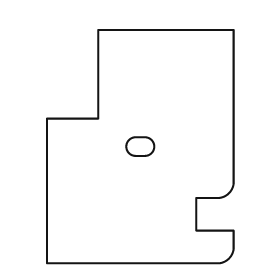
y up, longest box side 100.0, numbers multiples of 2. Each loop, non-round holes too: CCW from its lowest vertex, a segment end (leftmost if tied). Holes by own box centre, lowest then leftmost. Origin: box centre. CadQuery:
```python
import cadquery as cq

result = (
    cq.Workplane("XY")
    .moveTo(-40.0, -50.0)
    .lineTo(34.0, -50.0)
    .threePointArc((38.0, -48.0), (40.0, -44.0))
    .lineTo(40.0, -36.0)
    .lineTo(24.0, -36.0)
    .lineTo(24.0, -22.0)
    .lineTo(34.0, -22.0)
    .threePointArc((38.0, -20.0), (40.0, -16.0))
    .lineTo(40.0, 50.0)
    .lineTo(-18.0, 50.0)
    .lineTo(-18.0, 12.0)
    .lineTo(-40.0, 12.0)
    .close()
    .moveTo(-2.0, -4.0)
    .lineTo(2.0, -4.0)
    .threePointArc((6.0, 0.0), (2.0, 4.0))
    .lineTo(-2.0, 4.0)
    .threePointArc((-6.0, 0.0), (-2.0, -4.0))
    .close()
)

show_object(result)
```